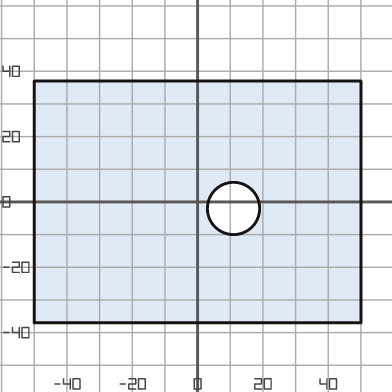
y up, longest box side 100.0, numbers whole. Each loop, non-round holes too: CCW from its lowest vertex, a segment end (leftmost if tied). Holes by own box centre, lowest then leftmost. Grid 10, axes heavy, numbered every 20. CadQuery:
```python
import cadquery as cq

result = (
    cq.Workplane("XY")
    .moveTo(-50.0, -37.0)
    .lineTo(50.0, -37.0)
    .lineTo(50.0, 37.0)
    .lineTo(-50.0, 37.0)
    .close()
    .moveTo(11.0, -2.0)
    .circle(8.0)
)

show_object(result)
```